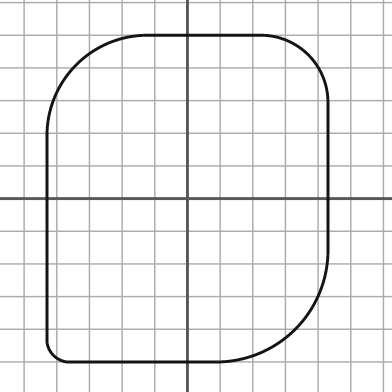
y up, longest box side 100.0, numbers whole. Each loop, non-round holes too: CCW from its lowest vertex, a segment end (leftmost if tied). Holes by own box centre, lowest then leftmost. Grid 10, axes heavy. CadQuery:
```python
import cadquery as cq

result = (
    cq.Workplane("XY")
    .moveTo(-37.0, -50.0)
    .lineTo(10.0, -50.0)
    .threePointArc((33.0, -40.0), (43.0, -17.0))
    .lineTo(43.0, 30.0)
    .threePointArc((37.0, 44.0), (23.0, 50.0))
    .lineTo(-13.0, 50.0)
    .threePointArc((-34.0, 41.0), (-43.0, 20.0))
    .lineTo(-43.0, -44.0)
    .threePointArc((-41.0, -48.0), (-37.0, -50.0))
    .close()
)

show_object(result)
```